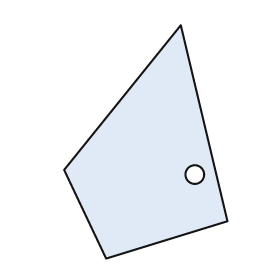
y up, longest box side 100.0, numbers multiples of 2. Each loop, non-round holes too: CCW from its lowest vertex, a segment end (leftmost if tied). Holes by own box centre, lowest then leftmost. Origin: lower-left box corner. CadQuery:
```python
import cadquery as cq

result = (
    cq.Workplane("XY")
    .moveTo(18.0, 0.0)
    .lineTo(70.0, 16.0)
    .lineTo(50.0, 100.0)
    .lineTo(0.0, 38.0)
    .close()
    .moveTo(56.0, 36.0)
    .circle(4.0)
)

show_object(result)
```